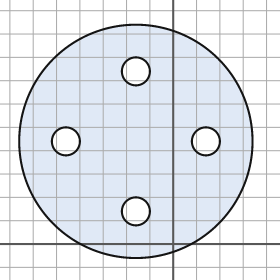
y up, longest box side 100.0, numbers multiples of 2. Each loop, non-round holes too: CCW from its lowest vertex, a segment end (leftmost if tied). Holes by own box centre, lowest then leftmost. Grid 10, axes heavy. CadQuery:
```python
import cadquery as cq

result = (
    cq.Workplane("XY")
    .moveTo(-16.0, 44.0)
    .circle(50.0)
    .moveTo(-16.0, 14.0)
    .circle(6.0)
    .moveTo(-46.0, 44.0)
    .circle(6.0)
    .moveTo(14.0, 44.0)
    .circle(6.0)
    .moveTo(-16.0, 74.0)
    .circle(6.0)
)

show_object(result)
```